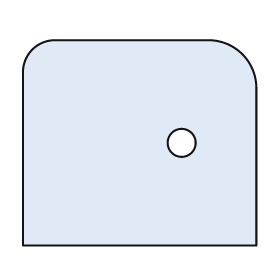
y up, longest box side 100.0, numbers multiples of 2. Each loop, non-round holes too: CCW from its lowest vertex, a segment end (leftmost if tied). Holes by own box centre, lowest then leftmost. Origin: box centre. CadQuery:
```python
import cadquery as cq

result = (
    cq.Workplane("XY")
    .moveTo(-50.0, -44.0)
    .lineTo(50.0, -44.0)
    .lineTo(50.0, 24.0)
    .threePointArc((44.0, 38.0), (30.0, 44.0))
    .lineTo(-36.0, 44.0)
    .threePointArc((-46.0, 40.0), (-50.0, 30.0))
    .close()
    .moveTo(18.0, 0.0)
    .circle(6.0)
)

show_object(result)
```